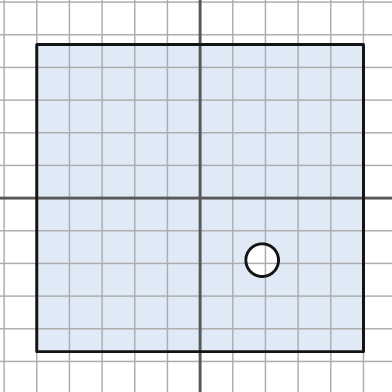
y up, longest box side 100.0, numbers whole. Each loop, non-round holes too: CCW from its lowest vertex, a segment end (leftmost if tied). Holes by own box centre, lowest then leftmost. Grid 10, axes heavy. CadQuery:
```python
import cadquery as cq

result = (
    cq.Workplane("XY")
    .moveTo(-50.0, -47.0)
    .lineTo(50.0, -47.0)
    .lineTo(50.0, 47.0)
    .lineTo(-50.0, 47.0)
    .close()
    .moveTo(19.0, -19.0)
    .circle(5.0)
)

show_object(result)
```